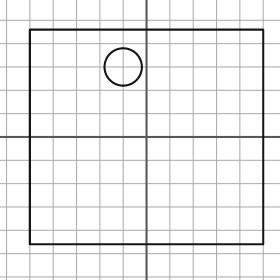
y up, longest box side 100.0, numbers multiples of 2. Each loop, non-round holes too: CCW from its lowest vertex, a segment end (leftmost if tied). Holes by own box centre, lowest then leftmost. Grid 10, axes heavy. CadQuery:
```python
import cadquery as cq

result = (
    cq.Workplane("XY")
    .moveTo(-50.0, -46.0)
    .lineTo(50.0, -46.0)
    .lineTo(50.0, 46.0)
    .lineTo(-50.0, 46.0)
    .close()
    .moveTo(-10.0, 30.0)
    .circle(8.0)
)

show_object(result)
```